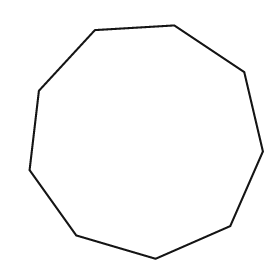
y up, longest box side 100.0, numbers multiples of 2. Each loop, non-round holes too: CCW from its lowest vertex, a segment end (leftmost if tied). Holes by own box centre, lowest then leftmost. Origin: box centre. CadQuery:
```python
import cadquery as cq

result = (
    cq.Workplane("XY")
    .moveTo(4.0, -50.0)
    .lineTo(36.0, -36.0)
    .lineTo(50.0, -4.0)
    .lineTo(42.0, 30.0)
    .lineTo(12.0, 50.0)
    .lineTo(-22.0, 48.0)
    .lineTo(-46.0, 22.0)
    .lineTo(-50.0, -12.0)
    .lineTo(-30.0, -40.0)
    .close()
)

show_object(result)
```